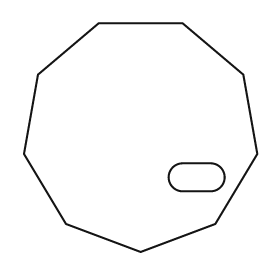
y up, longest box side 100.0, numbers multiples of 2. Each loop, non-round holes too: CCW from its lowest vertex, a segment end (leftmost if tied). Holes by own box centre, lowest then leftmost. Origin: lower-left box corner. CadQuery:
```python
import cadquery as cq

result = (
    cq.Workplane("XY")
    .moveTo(50.0, 0.0)
    .lineTo(82.0, 12.0)
    .lineTo(100.0, 42.0)
    .lineTo(94.0, 76.0)
    .lineTo(68.0, 98.0)
    .lineTo(32.0, 98.0)
    .lineTo(6.0, 76.0)
    .lineTo(0.0, 42.0)
    .lineTo(18.0, 12.0)
    .close()
    .moveTo(68.0, 26.0)
    .lineTo(80.0, 26.0)
    .threePointArc((86.0, 32.0), (80.0, 38.0))
    .lineTo(68.0, 38.0)
    .threePointArc((62.0, 32.0), (68.0, 26.0))
    .close()
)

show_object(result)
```